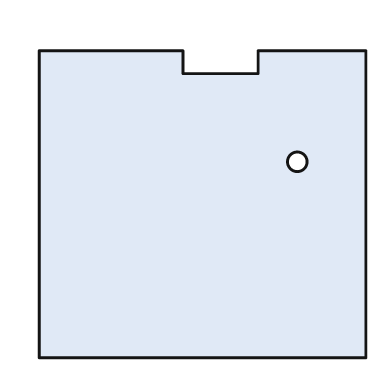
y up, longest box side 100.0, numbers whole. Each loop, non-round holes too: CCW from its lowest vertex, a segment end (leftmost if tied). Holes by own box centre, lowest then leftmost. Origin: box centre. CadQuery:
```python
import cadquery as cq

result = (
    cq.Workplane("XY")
    .moveTo(-50.0, -47.0)
    .lineTo(50.0, -47.0)
    .lineTo(50.0, 47.0)
    .lineTo(17.0, 47.0)
    .lineTo(17.0, 40.0)
    .lineTo(-6.0, 40.0)
    .lineTo(-6.0, 47.0)
    .lineTo(-50.0, 47.0)
    .close()
    .moveTo(29.0, 13.0)
    .circle(3.0)
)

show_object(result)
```